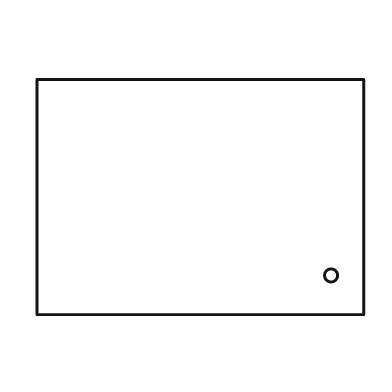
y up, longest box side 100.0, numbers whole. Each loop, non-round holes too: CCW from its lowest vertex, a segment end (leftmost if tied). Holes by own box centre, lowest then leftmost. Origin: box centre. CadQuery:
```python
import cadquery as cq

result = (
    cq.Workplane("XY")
    .moveTo(-50.0, -36.0)
    .lineTo(50.0, -36.0)
    .lineTo(50.0, 36.0)
    .lineTo(-50.0, 36.0)
    .close()
    .moveTo(40.0, -24.0)
    .circle(2.0)
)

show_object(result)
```